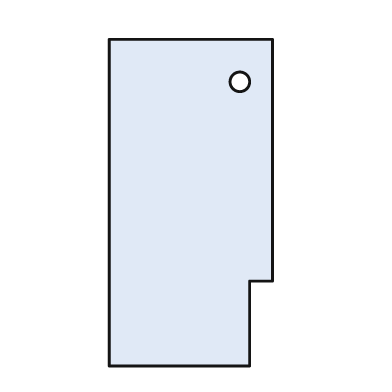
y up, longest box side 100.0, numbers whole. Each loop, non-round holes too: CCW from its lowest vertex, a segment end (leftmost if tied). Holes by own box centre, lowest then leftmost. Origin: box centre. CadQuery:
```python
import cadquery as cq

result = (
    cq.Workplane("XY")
    .moveTo(-25.0, -50.0)
    .lineTo(18.0, -50.0)
    .lineTo(18.0, -24.0)
    .lineTo(25.0, -24.0)
    .lineTo(25.0, 50.0)
    .lineTo(-25.0, 50.0)
    .close()
    .moveTo(15.0, 37.0)
    .circle(3.0)
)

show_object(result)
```